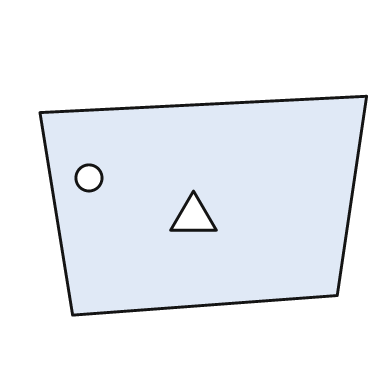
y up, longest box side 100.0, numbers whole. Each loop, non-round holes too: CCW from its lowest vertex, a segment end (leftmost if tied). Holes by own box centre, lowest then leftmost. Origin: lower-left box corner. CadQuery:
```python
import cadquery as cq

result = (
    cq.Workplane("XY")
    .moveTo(10.0, 0.0)
    .lineTo(91.0, 6.0)
    .lineTo(100.0, 67.0)
    .lineTo(0.0, 62.0)
    .close()
    .moveTo(40.0, 26.0)
    .lineTo(54.0, 26.0)
    .lineTo(47.0, 38.0)
    .close()
    .moveTo(15.0, 42.0)
    .circle(4.0)
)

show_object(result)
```